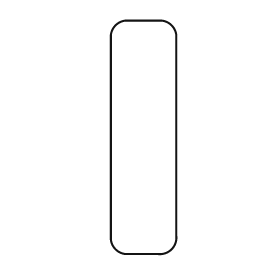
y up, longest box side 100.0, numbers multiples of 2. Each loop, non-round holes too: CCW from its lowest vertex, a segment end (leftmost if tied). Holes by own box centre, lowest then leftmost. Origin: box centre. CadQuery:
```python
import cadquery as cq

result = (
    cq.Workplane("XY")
    .moveTo(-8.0, -50.0)
    .lineTo(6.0, -50.0)
    .threePointArc((12.0, -48.0), (14.0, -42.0))
    .lineTo(14.0, 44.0)
    .threePointArc((12.0, 48.0), (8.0, 50.0))
    .lineTo(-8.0, 50.0)
    .threePointArc((-12.0, 48.0), (-14.0, 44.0))
    .lineTo(-14.0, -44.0)
    .threePointArc((-12.0, -48.0), (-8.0, -50.0))
    .close()
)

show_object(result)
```